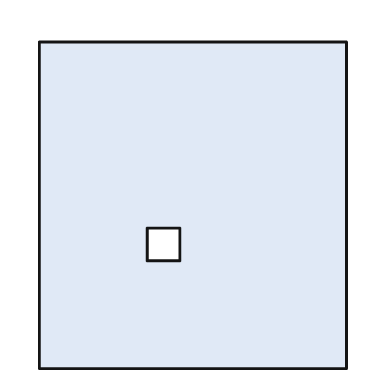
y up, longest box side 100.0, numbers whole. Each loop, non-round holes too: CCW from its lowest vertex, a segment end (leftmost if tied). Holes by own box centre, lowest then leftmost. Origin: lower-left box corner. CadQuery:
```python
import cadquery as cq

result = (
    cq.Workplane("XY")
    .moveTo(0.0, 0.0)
    .lineTo(94.0, 0.0)
    .lineTo(94.0, 100.0)
    .lineTo(0.0, 100.0)
    .close()
    .moveTo(33.0, 33.0)
    .lineTo(43.0, 33.0)
    .lineTo(43.0, 43.0)
    .lineTo(33.0, 43.0)
    .close()
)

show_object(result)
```